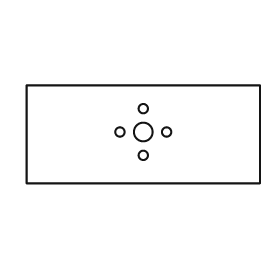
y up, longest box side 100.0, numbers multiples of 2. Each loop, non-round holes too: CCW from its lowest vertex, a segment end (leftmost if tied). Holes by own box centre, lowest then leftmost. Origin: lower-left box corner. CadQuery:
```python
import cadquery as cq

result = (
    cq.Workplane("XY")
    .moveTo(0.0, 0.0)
    .lineTo(100.0, 0.0)
    .lineTo(100.0, 42.0)
    .lineTo(0.0, 42.0)
    .close()
    .moveTo(50.0, 12.0)
    .circle(2.0)
    .moveTo(40.0, 22.0)
    .circle(2.0)
    .moveTo(50.0, 22.0)
    .circle(4.0)
    .moveTo(60.0, 22.0)
    .circle(2.0)
    .moveTo(50.0, 32.0)
    .circle(2.0)
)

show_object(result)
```